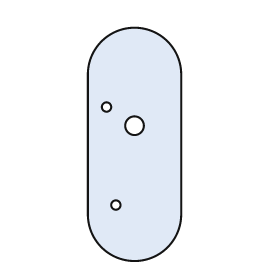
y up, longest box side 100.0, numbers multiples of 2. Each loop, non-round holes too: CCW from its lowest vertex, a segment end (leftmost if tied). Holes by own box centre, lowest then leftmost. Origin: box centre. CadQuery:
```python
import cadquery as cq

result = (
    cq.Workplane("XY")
    .moveTo(-20.0, -30.0)
    .threePointArc((0.0, -50.0), (20.0, -30.0))
    .lineTo(20.0, 30.0)
    .threePointArc((0.0, 50.0), (-20.0, 30.0))
    .close()
    .moveTo(-8.0, -26.0)
    .circle(2.0)
    .moveTo(0.0, 8.0)
    .circle(4.0)
    .moveTo(-12.0, 16.0)
    .circle(2.0)
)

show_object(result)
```